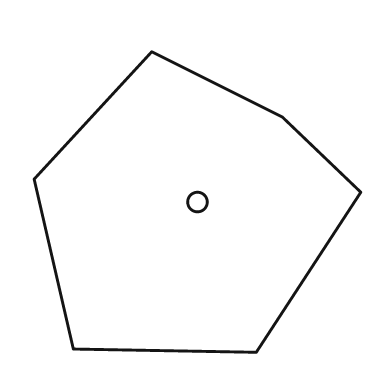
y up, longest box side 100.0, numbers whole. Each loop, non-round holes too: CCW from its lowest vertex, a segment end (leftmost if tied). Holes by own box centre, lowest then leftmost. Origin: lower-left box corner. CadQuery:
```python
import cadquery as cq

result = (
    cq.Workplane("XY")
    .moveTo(68.0, 0.0)
    .lineTo(100.0, 49.0)
    .lineTo(76.0, 72.0)
    .lineTo(36.0, 92.0)
    .lineTo(0.0, 53.0)
    .lineTo(12.0, 1.0)
    .close()
    .moveTo(50.0, 46.0)
    .circle(3.0)
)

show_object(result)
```